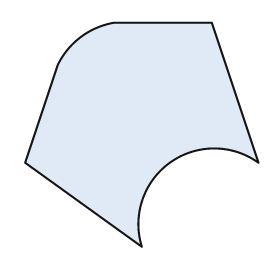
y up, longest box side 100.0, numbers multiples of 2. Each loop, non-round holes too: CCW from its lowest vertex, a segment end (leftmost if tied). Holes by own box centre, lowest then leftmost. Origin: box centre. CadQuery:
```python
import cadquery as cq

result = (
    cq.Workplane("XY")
    .moveTo(0.0, -48.0)
    .threePointArc((12.0, -12.0), (50.0, -12.0))
    .lineTo(30.0, 48.0)
    .lineTo(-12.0, 48.0)
    .threePointArc((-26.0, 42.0), (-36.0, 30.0))
    .lineTo(-50.0, -12.0)
    .close()
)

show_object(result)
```